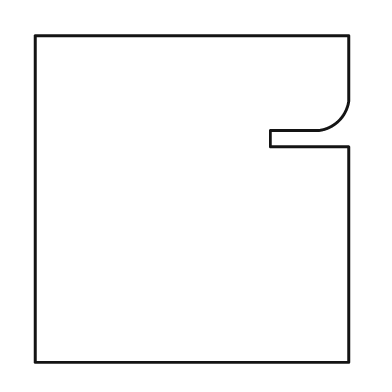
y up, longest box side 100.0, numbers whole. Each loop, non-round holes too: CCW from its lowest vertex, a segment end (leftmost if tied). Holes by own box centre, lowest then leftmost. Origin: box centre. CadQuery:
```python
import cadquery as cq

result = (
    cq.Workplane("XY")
    .moveTo(-48.0, -50.0)
    .lineTo(48.0, -50.0)
    .lineTo(48.0, 16.0)
    .lineTo(24.0, 16.0)
    .lineTo(24.0, 21.0)
    .lineTo(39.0, 21.0)
    .threePointArc((45.0, 24.0), (48.0, 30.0))
    .lineTo(48.0, 50.0)
    .lineTo(-48.0, 50.0)
    .close()
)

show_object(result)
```